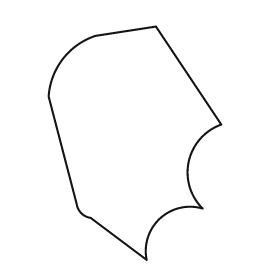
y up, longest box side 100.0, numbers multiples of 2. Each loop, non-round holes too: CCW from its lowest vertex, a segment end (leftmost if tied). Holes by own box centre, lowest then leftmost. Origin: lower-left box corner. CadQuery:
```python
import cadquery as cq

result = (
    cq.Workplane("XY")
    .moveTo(42.0, 0.0)
    .threePointArc((48.0, 18.0), (66.0, 22.0))
    .threePointArc((60.0, 42.0), (74.0, 58.0))
    .lineTo(46.0, 100.0)
    .lineTo(20.0, 96.0)
    .threePointArc((6.0, 86.0), (0.0, 70.0))
    .lineTo(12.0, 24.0)
    .threePointArc((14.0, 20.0), (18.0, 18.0))
    .close()
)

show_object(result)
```